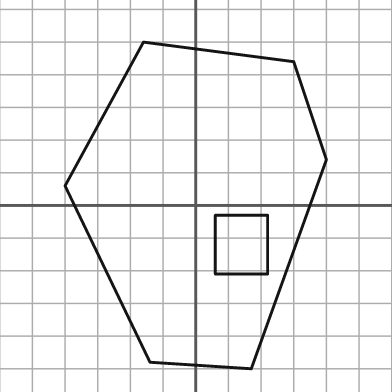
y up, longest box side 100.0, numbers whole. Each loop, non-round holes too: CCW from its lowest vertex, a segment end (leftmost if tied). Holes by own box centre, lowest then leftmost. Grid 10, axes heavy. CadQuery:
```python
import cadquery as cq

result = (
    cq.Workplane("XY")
    .moveTo(17.0, -50.0)
    .lineTo(40.0, 14.0)
    .lineTo(30.0, 44.0)
    .lineTo(-16.0, 50.0)
    .lineTo(-40.0, 6.0)
    .lineTo(-14.0, -48.0)
    .close()
    .moveTo(6.0, -21.0)
    .lineTo(22.0, -21.0)
    .lineTo(22.0, -3.0)
    .lineTo(6.0, -3.0)
    .close()
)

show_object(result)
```